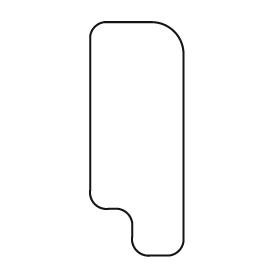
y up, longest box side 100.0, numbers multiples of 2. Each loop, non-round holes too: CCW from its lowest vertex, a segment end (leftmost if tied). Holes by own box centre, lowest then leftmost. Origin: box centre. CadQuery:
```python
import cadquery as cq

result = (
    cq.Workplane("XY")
    .moveTo(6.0, -50.0)
    .lineTo(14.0, -50.0)
    .threePointArc((18.0, -48.0), (20.0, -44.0))
    .lineTo(20.0, 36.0)
    .threePointArc((16.0, 46.0), (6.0, 50.0))
    .lineTo(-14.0, 50.0)
    .threePointArc((-18.0, 48.0), (-20.0, 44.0))
    .lineTo(-20.0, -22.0)
    .threePointArc((-18.0, -28.0), (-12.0, -30.0))
    .lineTo(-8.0, -30.0)
    .threePointArc((-4.0, -32.0), (-2.0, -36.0))
    .lineTo(-2.0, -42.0)
    .threePointArc((0.0, -48.0), (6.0, -50.0))
    .close()
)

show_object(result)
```